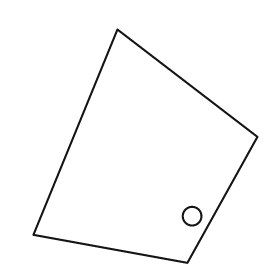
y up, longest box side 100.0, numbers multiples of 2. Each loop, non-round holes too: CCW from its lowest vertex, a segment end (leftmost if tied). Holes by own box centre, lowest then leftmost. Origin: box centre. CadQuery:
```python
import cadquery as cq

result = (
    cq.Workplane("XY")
    .moveTo(18.0, -50.0)
    .lineTo(48.0, 4.0)
    .lineTo(-12.0, 50.0)
    .lineTo(-48.0, -38.0)
    .close()
    .moveTo(20.0, -30.0)
    .circle(4.0)
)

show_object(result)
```